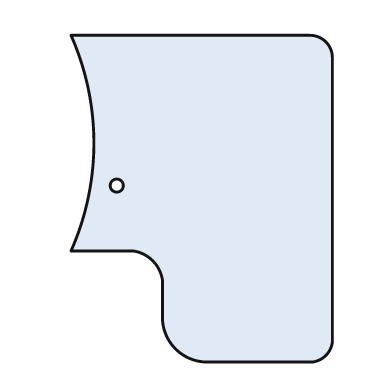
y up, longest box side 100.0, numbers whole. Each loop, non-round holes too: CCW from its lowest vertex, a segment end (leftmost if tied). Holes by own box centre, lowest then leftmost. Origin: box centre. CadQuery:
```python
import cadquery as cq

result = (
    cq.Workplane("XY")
    .moveTo(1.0, -50.0)
    .lineTo(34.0, -50.0)
    .threePointArc((38.0, -48.0), (40.0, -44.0))
    .lineTo(40.0, 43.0)
    .threePointArc((38.0, 48.0), (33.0, 50.0))
    .lineTo(-40.0, 50.0)
    .threePointArc((-33.0, 17.0), (-40.0, -16.0))
    .lineTo(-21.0, -16.0)
    .threePointArc((-15.0, -19.0), (-12.0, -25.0))
    .lineTo(-12.0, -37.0)
    .threePointArc((-8.0, -46.0), (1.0, -50.0))
    .close()
    .moveTo(-26.0, 4.0)
    .circle(2.0)
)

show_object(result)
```